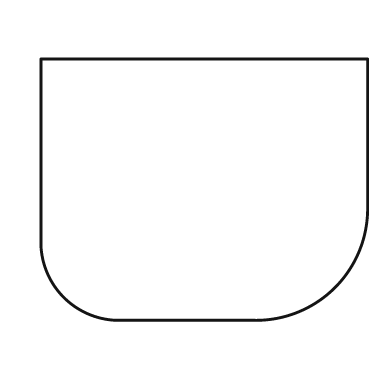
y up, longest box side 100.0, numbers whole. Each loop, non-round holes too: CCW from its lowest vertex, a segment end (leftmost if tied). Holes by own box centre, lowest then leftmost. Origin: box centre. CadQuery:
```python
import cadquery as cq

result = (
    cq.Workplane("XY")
    .moveTo(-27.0, -40.0)
    .lineTo(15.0, -40.0)
    .threePointArc((40.0, -30.0), (50.0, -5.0))
    .lineTo(50.0, 40.0)
    .lineTo(-50.0, 40.0)
    .lineTo(-50.0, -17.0)
    .threePointArc((-43.0, -33.0), (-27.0, -40.0))
    .close()
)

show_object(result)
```